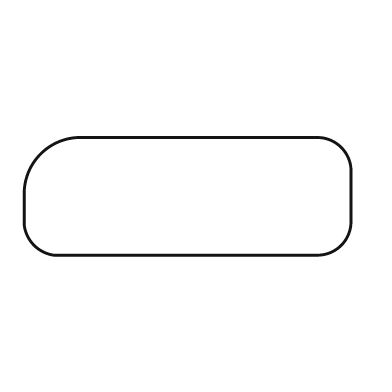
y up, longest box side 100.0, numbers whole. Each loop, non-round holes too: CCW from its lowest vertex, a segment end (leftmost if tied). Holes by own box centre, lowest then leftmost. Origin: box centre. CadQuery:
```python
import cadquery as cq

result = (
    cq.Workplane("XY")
    .moveTo(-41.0, -18.0)
    .lineTo(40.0, -18.0)
    .threePointArc((47.0, -15.0), (50.0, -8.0))
    .lineTo(50.0, 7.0)
    .threePointArc((47.0, 15.0), (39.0, 18.0))
    .lineTo(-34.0, 18.0)
    .threePointArc((-45.0, 13.0), (-50.0, 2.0))
    .lineTo(-50.0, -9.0)
    .threePointArc((-47.0, -15.0), (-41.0, -18.0))
    .close()
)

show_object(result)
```